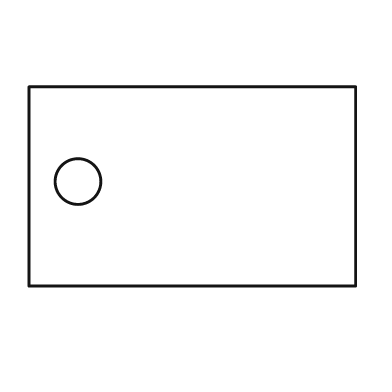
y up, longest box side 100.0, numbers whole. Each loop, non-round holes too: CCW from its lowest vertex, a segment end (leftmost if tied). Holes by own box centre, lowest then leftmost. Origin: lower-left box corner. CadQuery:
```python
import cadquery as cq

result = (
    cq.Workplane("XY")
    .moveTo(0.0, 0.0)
    .lineTo(100.0, 0.0)
    .lineTo(100.0, 61.0)
    .lineTo(0.0, 61.0)
    .close()
    .moveTo(15.0, 32.0)
    .circle(7.0)
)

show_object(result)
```